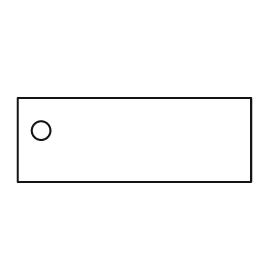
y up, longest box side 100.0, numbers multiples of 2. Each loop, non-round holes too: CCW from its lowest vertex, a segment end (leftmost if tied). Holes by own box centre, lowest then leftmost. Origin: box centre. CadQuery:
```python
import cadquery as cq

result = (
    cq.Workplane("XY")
    .moveTo(-50.0, -18.0)
    .lineTo(50.0, -18.0)
    .lineTo(50.0, 18.0)
    .lineTo(-50.0, 18.0)
    .close()
    .moveTo(-40.0, 4.0)
    .circle(4.0)
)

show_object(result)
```